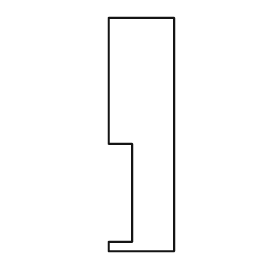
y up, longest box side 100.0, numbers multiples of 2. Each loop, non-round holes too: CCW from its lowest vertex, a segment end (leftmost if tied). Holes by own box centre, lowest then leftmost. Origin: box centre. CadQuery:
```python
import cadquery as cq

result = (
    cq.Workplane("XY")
    .moveTo(-14.0, -50.0)
    .lineTo(14.0, -50.0)
    .lineTo(14.0, 50.0)
    .lineTo(-14.0, 50.0)
    .lineTo(-14.0, -4.0)
    .lineTo(-4.0, -4.0)
    .lineTo(-4.0, -46.0)
    .lineTo(-14.0, -46.0)
    .close()
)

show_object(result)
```